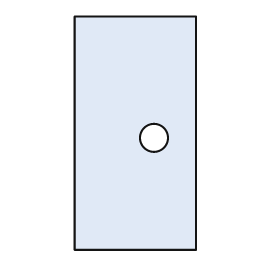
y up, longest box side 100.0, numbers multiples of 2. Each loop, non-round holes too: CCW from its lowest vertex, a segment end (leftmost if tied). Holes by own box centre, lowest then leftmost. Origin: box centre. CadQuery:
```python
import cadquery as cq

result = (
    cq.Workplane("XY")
    .moveTo(-26.0, -50.0)
    .lineTo(26.0, -50.0)
    .lineTo(26.0, 50.0)
    .lineTo(-26.0, 50.0)
    .close()
    .moveTo(8.0, -2.0)
    .circle(6.0)
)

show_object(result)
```